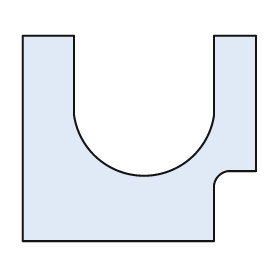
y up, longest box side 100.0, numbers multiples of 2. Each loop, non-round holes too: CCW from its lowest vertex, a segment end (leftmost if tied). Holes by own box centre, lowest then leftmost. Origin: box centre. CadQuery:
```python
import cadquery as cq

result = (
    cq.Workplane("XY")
    .moveTo(-50.0, -44.0)
    .lineTo(32.0, -44.0)
    .lineTo(32.0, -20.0)
    .threePointArc((34.0, -16.0), (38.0, -14.0))
    .lineTo(50.0, -14.0)
    .lineTo(50.0, 44.0)
    .lineTo(32.0, 44.0)
    .lineTo(32.0, 10.0)
    .threePointArc((2.0, -16.0), (-28.0, 10.0))
    .lineTo(-28.0, 44.0)
    .lineTo(-50.0, 44.0)
    .close()
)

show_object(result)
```